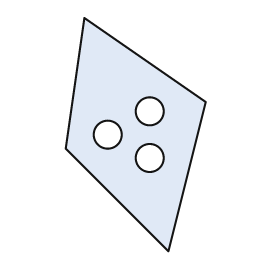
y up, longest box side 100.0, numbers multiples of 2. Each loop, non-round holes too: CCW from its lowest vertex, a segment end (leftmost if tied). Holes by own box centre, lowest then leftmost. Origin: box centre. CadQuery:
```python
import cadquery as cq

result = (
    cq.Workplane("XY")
    .moveTo(14.0, -50.0)
    .lineTo(30.0, 14.0)
    .lineTo(-22.0, 50.0)
    .lineTo(-30.0, -6.0)
    .close()
    .moveTo(6.0, -10.0)
    .circle(6.0)
    .moveTo(-12.0, 0.0)
    .circle(6.0)
    .moveTo(6.0, 10.0)
    .circle(6.0)
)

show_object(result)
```